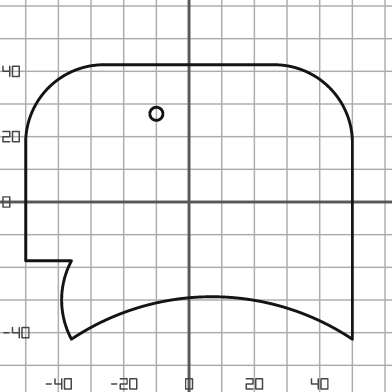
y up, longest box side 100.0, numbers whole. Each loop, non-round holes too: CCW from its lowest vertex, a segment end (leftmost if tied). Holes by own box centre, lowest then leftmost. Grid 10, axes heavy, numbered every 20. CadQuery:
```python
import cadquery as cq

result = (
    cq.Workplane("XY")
    .moveTo(-36.0, -42.0)
    .threePointArc((7.0, -29.0), (50.0, -42.0))
    .lineTo(50.0, 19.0)
    .threePointArc((43.0, 35.0), (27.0, 42.0))
    .lineTo(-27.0, 42.0)
    .threePointArc((-43.0, 35.0), (-50.0, 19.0))
    .lineTo(-50.0, -18.0)
    .lineTo(-36.0, -18.0)
    .threePointArc((-39.0, -30.0), (-36.0, -42.0))
    .close()
    .moveTo(-10.0, 27.0)
    .circle(2.0)
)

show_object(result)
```